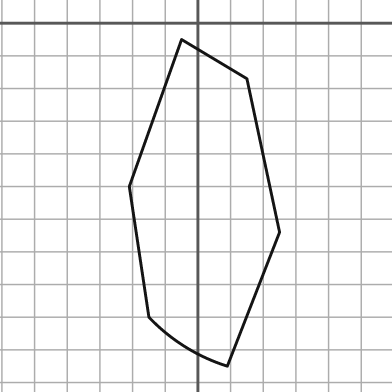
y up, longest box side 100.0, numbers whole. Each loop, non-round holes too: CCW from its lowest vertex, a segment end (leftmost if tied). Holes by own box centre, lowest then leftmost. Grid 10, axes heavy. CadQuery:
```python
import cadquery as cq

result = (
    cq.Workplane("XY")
    .moveTo(9.0, -105.0)
    .lineTo(25.0, -64.0)
    .lineTo(15.0, -17.0)
    .lineTo(-5.0, -5.0)
    .lineTo(-21.0, -50.0)
    .lineTo(-15.0, -90.0)
    .threePointArc((-4.0, -99.0), (9.0, -105.0))
    .close()
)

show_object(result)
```